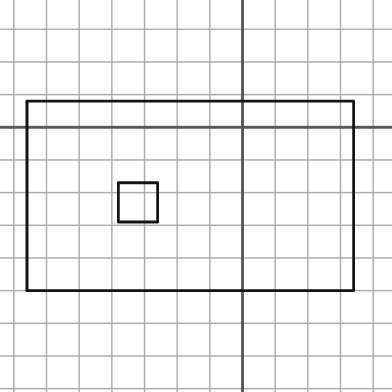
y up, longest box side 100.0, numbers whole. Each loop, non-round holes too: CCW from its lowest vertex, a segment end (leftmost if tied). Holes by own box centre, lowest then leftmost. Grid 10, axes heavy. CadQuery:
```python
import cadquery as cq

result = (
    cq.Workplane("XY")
    .moveTo(-66.0, -50.0)
    .lineTo(34.0, -50.0)
    .lineTo(34.0, 8.0)
    .lineTo(-66.0, 8.0)
    .close()
    .moveTo(-38.0, -29.0)
    .lineTo(-26.0, -29.0)
    .lineTo(-26.0, -17.0)
    .lineTo(-38.0, -17.0)
    .close()
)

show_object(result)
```